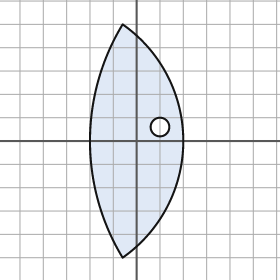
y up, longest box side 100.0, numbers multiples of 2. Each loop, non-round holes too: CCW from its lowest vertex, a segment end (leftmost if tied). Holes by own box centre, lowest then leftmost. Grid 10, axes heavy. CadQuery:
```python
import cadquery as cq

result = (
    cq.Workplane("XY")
    .moveTo(-6.0, -50.0)
    .threePointArc((20.0, 0.0), (-6.0, 50.0))
    .threePointArc((-20.0, 0.0), (-6.0, -50.0))
    .close()
    .moveTo(10.0, 6.0)
    .circle(4.0)
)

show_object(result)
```